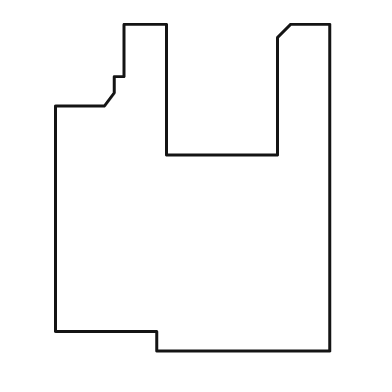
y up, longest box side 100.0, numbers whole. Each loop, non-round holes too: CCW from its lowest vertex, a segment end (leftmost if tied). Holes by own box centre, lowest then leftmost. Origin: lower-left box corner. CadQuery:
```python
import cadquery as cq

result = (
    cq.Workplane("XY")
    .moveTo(31.0, 0.0)
    .lineTo(84.0, 0.0)
    .lineTo(84.0, 100.0)
    .lineTo(72.0, 100.0)
    .lineTo(68.0, 96.0)
    .lineTo(68.0, 60.0)
    .lineTo(34.0, 60.0)
    .lineTo(34.0, 100.0)
    .lineTo(21.0, 100.0)
    .lineTo(21.0, 84.0)
    .lineTo(18.0, 84.0)
    .lineTo(18.0, 79.0)
    .lineTo(15.0, 75.0)
    .lineTo(0.0, 75.0)
    .lineTo(0.0, 6.0)
    .lineTo(31.0, 6.0)
    .close()
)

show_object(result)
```